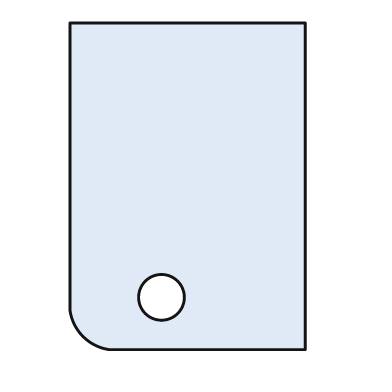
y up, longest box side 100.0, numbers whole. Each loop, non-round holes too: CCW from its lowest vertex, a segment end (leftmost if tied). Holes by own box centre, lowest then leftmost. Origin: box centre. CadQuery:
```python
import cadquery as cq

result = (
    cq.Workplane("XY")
    .moveTo(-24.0, -50.0)
    .lineTo(36.0, -50.0)
    .lineTo(36.0, 50.0)
    .lineTo(-36.0, 50.0)
    .lineTo(-36.0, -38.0)
    .threePointArc((-32.0, -46.0), (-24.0, -50.0))
    .close()
    .moveTo(-8.0, -34.0)
    .circle(7.0)
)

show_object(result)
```